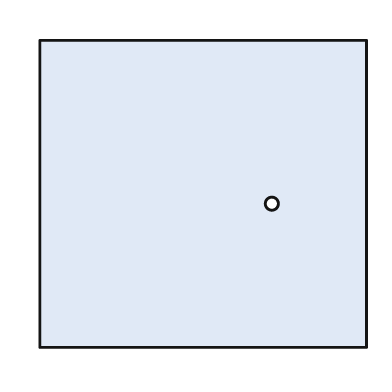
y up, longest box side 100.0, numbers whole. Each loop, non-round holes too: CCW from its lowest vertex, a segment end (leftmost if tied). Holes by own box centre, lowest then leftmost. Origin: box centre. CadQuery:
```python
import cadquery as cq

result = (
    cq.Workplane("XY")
    .moveTo(-50.0, -47.0)
    .lineTo(50.0, -47.0)
    .lineTo(50.0, 47.0)
    .lineTo(-50.0, 47.0)
    .close()
    .moveTo(21.0, -3.0)
    .circle(2.0)
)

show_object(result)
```